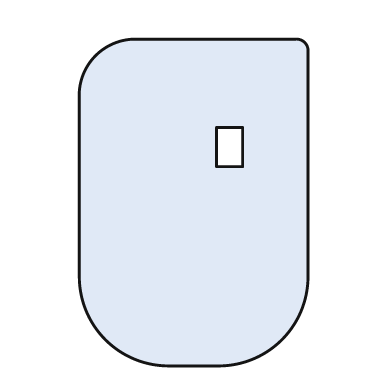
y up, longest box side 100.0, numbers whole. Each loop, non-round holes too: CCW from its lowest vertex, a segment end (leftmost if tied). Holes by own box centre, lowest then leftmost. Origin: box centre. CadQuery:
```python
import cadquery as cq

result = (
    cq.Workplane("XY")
    .moveTo(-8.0, -50.0)
    .lineTo(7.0, -50.0)
    .threePointArc((27.0, -42.0), (35.0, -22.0))
    .lineTo(35.0, 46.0)
    .threePointArc((34.0, 49.0), (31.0, 50.0))
    .lineTo(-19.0, 50.0)
    .threePointArc((-30.0, 45.0), (-35.0, 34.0))
    .lineTo(-35.0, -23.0)
    .threePointArc((-27.0, -42.0), (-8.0, -50.0))
    .close()
    .moveTo(7.0, 11.0)
    .lineTo(15.0, 11.0)
    .lineTo(15.0, 23.0)
    .lineTo(7.0, 23.0)
    .close()
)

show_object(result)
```